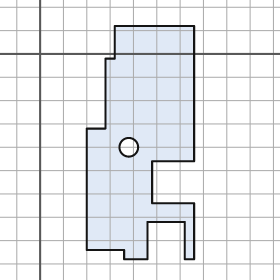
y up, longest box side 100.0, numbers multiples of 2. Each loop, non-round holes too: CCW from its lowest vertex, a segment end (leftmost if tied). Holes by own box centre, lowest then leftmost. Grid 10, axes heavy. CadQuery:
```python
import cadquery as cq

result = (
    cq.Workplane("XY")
    .moveTo(36.0, -88.0)
    .lineTo(46.0, -88.0)
    .lineTo(46.0, -72.0)
    .lineTo(62.0, -72.0)
    .lineTo(62.0, -88.0)
    .lineTo(66.0, -88.0)
    .lineTo(66.0, -64.0)
    .lineTo(48.0, -64.0)
    .lineTo(48.0, -46.0)
    .lineTo(66.0, -46.0)
    .lineTo(66.0, 12.0)
    .lineTo(32.0, 12.0)
    .lineTo(32.0, -2.0)
    .lineTo(28.0, -2.0)
    .lineTo(28.0, -32.0)
    .lineTo(20.0, -32.0)
    .lineTo(20.0, -84.0)
    .lineTo(36.0, -84.0)
    .close()
    .moveTo(38.0, -40.0)
    .circle(4.0)
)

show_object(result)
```